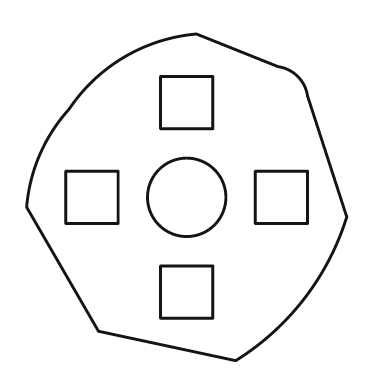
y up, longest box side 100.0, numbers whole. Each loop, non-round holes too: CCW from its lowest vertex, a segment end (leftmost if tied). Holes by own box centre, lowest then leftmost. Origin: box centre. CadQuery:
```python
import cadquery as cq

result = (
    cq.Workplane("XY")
    .moveTo(15.0, -50.0)
    .threePointArc((36.0, -31.0), (49.0, -6.0))
    .lineTo(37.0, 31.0)
    .threePointArc((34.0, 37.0), (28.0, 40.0))
    .lineTo(3.0, 50.0)
    .threePointArc((-19.0, 43.0), (-36.0, 27.0))
    .threePointArc((-45.0, 13.0), (-49.0, -3.0))
    .lineTo(-27.0, -41.0)
    .close()
    .moveTo(-8.0, -37.0)
    .lineTo(8.0, -37.0)
    .lineTo(8.0, -21.0)
    .lineTo(-8.0, -21.0)
    .close()
    .moveTo(-37.0, -8.0)
    .lineTo(-21.0, -8.0)
    .lineTo(-21.0, 8.0)
    .lineTo(-37.0, 8.0)
    .close()
    .moveTo(0.0, 0.0)
    .circle(12.0)
    .moveTo(21.0, -8.0)
    .lineTo(37.0, -8.0)
    .lineTo(37.0, 8.0)
    .lineTo(21.0, 8.0)
    .close()
    .moveTo(-8.0, 21.0)
    .lineTo(8.0, 21.0)
    .lineTo(8.0, 37.0)
    .lineTo(-8.0, 37.0)
    .close()
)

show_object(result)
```